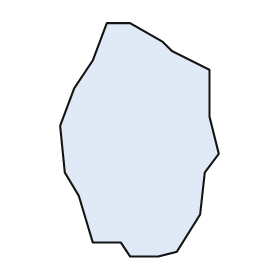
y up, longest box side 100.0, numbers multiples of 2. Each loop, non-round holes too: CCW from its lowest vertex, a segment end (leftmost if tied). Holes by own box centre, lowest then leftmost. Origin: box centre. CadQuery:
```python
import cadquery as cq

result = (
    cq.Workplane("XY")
    .moveTo(-4.0, -50.0)
    .lineTo(8.0, -50.0)
    .lineTo(16.0, -48.0)
    .lineTo(26.0, -32.0)
    .lineTo(28.0, -14.0)
    .lineTo(34.0, -6.0)
    .lineTo(30.0, 10.0)
    .lineTo(30.0, 30.0)
    .lineTo(14.0, 38.0)
    .lineTo(10.0, 42.0)
    .lineTo(-4.0, 50.0)
    .lineTo(-14.0, 50.0)
    .lineTo(-20.0, 34.0)
    .lineTo(-28.0, 22.0)
    .lineTo(-34.0, 6.0)
    .lineTo(-32.0, -14.0)
    .lineTo(-26.0, -24.0)
    .lineTo(-20.0, -44.0)
    .lineTo(-8.0, -44.0)
    .close()
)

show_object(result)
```